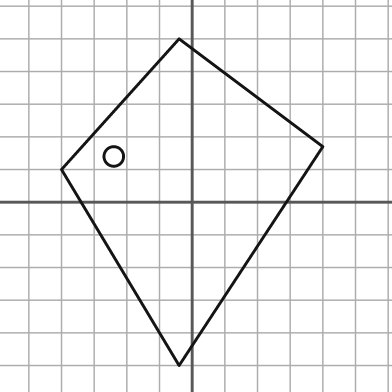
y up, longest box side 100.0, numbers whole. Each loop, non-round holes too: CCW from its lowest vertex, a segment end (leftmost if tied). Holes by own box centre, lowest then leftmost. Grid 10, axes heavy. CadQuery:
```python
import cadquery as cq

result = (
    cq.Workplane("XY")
    .moveTo(-4.0, -50.0)
    .lineTo(40.0, 17.0)
    .lineTo(-4.0, 50.0)
    .lineTo(-40.0, 10.0)
    .close()
    .moveTo(-24.0, 14.0)
    .circle(3.0)
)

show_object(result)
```